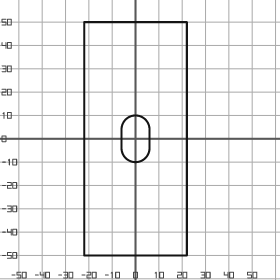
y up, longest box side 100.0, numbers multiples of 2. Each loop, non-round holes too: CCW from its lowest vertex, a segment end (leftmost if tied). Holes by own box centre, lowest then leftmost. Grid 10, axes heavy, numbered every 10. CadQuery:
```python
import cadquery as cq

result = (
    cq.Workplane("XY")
    .moveTo(-22.0, -50.0)
    .lineTo(22.0, -50.0)
    .lineTo(22.0, 50.0)
    .lineTo(-22.0, 50.0)
    .close()
    .moveTo(-6.0, -4.0)
    .threePointArc((0.0, -10.0), (6.0, -4.0))
    .lineTo(6.0, 4.0)
    .threePointArc((0.0, 10.0), (-6.0, 4.0))
    .close()
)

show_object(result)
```